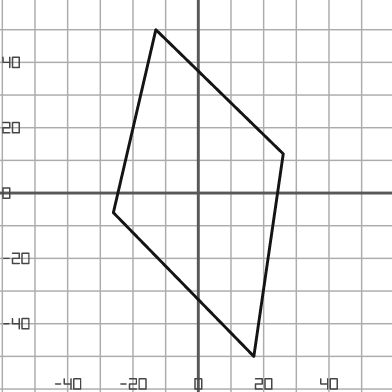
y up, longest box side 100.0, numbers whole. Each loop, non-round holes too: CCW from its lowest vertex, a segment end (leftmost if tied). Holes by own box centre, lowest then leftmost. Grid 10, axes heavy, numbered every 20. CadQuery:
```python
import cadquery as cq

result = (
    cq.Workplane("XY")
    .moveTo(17.0, -50.0)
    .lineTo(26.0, 12.0)
    .lineTo(-13.0, 50.0)
    .lineTo(-26.0, -6.0)
    .close()
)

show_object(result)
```